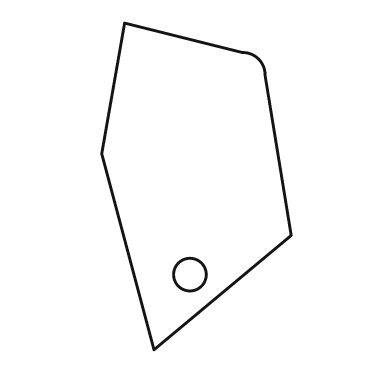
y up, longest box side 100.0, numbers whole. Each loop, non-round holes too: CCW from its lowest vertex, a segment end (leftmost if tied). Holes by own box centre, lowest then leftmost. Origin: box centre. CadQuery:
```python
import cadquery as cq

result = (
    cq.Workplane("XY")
    .moveTo(-13.0, -50.0)
    .lineTo(29.0, -15.0)
    .lineTo(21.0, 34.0)
    .threePointArc((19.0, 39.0), (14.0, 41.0))
    .lineTo(-22.0, 50.0)
    .lineTo(-29.0, 10.0)
    .close()
    .moveTo(-2.0, -27.0)
    .circle(5.0)
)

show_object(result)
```